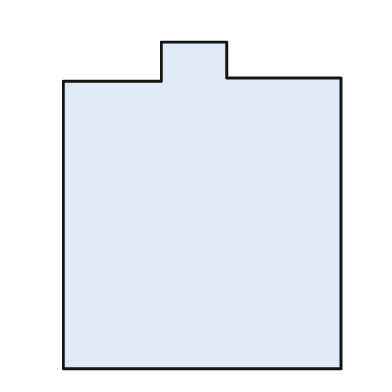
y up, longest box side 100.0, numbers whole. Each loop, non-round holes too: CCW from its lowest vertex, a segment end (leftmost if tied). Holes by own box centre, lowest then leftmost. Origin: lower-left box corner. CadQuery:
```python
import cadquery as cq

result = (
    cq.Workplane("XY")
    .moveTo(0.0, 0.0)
    .lineTo(85.0, 0.0)
    .lineTo(85.0, 89.0)
    .lineTo(50.0, 89.0)
    .lineTo(50.0, 100.0)
    .lineTo(30.0, 100.0)
    .lineTo(30.0, 88.0)
    .lineTo(0.0, 88.0)
    .close()
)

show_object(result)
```